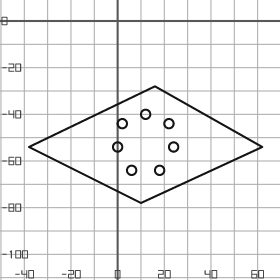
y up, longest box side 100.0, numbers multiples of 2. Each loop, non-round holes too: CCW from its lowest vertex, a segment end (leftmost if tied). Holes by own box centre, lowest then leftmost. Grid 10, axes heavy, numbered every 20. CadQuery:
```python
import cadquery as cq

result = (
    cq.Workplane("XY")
    .moveTo(10.0, -78.0)
    .lineTo(62.0, -54.0)
    .lineTo(16.0, -28.0)
    .lineTo(-38.0, -54.0)
    .close()
    .moveTo(6.0, -64.0)
    .circle(2.0)
    .moveTo(18.0, -64.0)
    .circle(2.0)
    .moveTo(0.0, -54.0)
    .circle(2.0)
    .moveTo(24.0, -54.0)
    .circle(2.0)
    .moveTo(2.0, -44.0)
    .circle(2.0)
    .moveTo(22.0, -44.0)
    .circle(2.0)
    .moveTo(12.0, -40.0)
    .circle(2.0)
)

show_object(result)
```